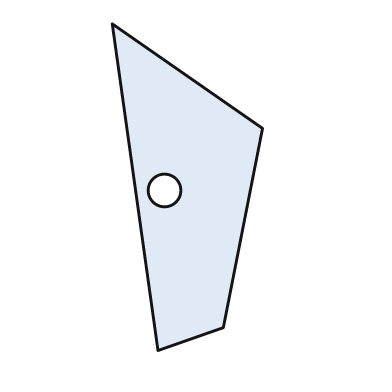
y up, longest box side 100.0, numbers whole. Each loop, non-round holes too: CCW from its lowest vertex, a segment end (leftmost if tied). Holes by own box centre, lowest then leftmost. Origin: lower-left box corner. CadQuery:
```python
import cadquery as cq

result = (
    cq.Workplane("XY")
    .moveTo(14.0, 0.0)
    .lineTo(34.0, 7.0)
    .lineTo(46.0, 68.0)
    .lineTo(0.0, 100.0)
    .close()
    .moveTo(16.0, 49.0)
    .circle(5.0)
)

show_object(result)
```